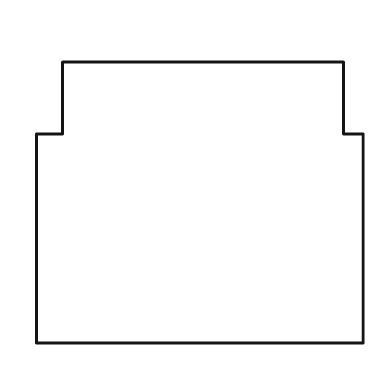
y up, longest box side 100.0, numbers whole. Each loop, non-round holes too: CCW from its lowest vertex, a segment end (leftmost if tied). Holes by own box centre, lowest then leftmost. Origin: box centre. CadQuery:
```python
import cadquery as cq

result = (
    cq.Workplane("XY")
    .moveTo(-50.0, -43.0)
    .lineTo(50.0, -43.0)
    .lineTo(50.0, 21.0)
    .lineTo(44.0, 21.0)
    .lineTo(44.0, 43.0)
    .lineTo(-42.0, 43.0)
    .lineTo(-42.0, 21.0)
    .lineTo(-50.0, 21.0)
    .close()
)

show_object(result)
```